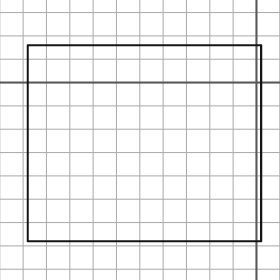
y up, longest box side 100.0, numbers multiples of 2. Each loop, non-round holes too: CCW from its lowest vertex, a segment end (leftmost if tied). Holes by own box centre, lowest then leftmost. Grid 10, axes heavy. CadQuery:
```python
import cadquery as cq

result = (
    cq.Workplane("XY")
    .moveTo(-98.0, -68.0)
    .lineTo(2.0, -68.0)
    .lineTo(2.0, 16.0)
    .lineTo(-98.0, 16.0)
    .close()
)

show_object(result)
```